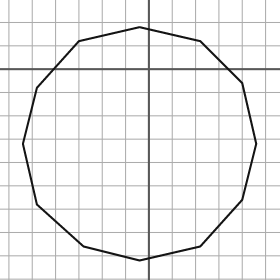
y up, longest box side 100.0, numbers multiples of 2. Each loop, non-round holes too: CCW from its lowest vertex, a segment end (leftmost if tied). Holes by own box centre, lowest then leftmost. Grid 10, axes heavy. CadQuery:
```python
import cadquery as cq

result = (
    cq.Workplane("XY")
    .moveTo(-4.0, -82.0)
    .lineTo(22.0, -76.0)
    .lineTo(40.0, -56.0)
    .lineTo(46.0, -32.0)
    .lineTo(40.0, -6.0)
    .lineTo(22.0, 12.0)
    .lineTo(-4.0, 18.0)
    .lineTo(-30.0, 12.0)
    .lineTo(-48.0, -8.0)
    .lineTo(-54.0, -32.0)
    .lineTo(-48.0, -58.0)
    .lineTo(-28.0, -76.0)
    .close()
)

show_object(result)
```